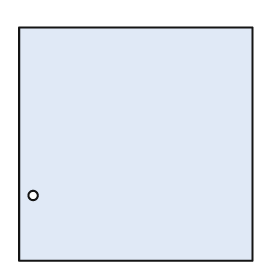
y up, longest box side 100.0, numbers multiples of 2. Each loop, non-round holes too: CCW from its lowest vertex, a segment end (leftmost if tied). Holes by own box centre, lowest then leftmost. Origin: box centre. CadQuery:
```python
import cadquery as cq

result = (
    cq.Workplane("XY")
    .moveTo(-50.0, -50.0)
    .lineTo(50.0, -50.0)
    .lineTo(50.0, 50.0)
    .lineTo(-50.0, 50.0)
    .close()
    .moveTo(-44.0, -22.0)
    .circle(2.0)
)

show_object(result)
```